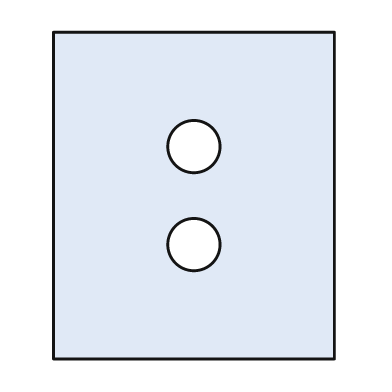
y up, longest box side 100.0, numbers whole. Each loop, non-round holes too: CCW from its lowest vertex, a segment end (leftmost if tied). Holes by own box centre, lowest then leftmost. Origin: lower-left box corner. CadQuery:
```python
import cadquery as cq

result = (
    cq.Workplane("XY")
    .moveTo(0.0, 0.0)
    .lineTo(86.0, 0.0)
    .lineTo(86.0, 100.0)
    .lineTo(0.0, 100.0)
    .close()
    .moveTo(43.0, 35.0)
    .circle(8.0)
    .moveTo(43.0, 65.0)
    .circle(8.0)
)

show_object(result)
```